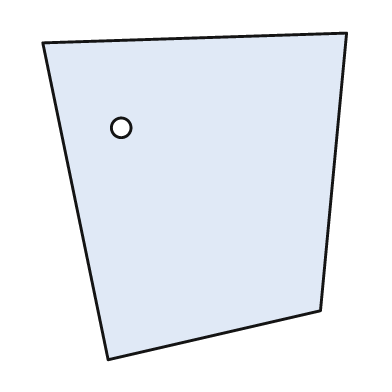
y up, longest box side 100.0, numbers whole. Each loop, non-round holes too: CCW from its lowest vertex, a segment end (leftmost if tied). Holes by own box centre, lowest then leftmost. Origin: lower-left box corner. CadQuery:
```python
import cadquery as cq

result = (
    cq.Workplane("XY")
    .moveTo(20.0, 0.0)
    .lineTo(85.0, 15.0)
    .lineTo(93.0, 100.0)
    .lineTo(0.0, 97.0)
    .close()
    .moveTo(24.0, 71.0)
    .circle(3.0)
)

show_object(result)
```